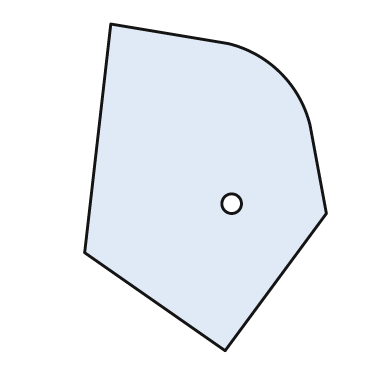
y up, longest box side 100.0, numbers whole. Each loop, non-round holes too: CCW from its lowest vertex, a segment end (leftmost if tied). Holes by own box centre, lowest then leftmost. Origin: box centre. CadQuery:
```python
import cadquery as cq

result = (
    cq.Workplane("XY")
    .moveTo(6.0, -50.0)
    .lineTo(37.0, -8.0)
    .lineTo(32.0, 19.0)
    .threePointArc((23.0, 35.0), (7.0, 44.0))
    .lineTo(-29.0, 50.0)
    .lineTo(-37.0, -20.0)
    .close()
    .moveTo(8.0, -5.0)
    .circle(3.0)
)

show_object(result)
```